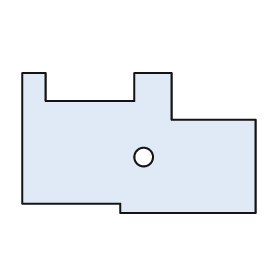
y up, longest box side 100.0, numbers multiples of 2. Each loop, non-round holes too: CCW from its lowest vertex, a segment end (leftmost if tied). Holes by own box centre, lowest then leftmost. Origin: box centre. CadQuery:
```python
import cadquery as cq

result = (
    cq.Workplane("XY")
    .moveTo(-8.0, -30.0)
    .lineTo(50.0, -30.0)
    .lineTo(50.0, 10.0)
    .lineTo(14.0, 10.0)
    .lineTo(14.0, 30.0)
    .lineTo(-2.0, 30.0)
    .lineTo(-2.0, 18.0)
    .lineTo(-40.0, 18.0)
    .lineTo(-40.0, 30.0)
    .lineTo(-50.0, 30.0)
    .lineTo(-50.0, -26.0)
    .lineTo(-8.0, -26.0)
    .close()
    .moveTo(2.0, -6.0)
    .circle(4.0)
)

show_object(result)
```